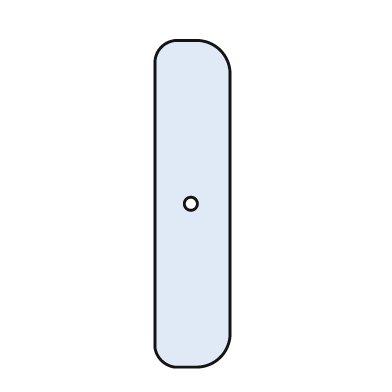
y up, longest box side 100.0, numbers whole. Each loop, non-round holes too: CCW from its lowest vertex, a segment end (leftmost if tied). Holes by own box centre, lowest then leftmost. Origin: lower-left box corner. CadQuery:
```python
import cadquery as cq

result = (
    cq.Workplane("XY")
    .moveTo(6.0, 0.0)
    .lineTo(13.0, 0.0)
    .threePointArc((20.0, 3.0), (23.0, 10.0))
    .lineTo(23.0, 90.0)
    .threePointArc((20.0, 97.0), (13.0, 100.0))
    .lineTo(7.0, 100.0)
    .threePointArc((2.0, 98.0), (0.0, 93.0))
    .lineTo(0.0, 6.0)
    .threePointArc((2.0, 2.0), (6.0, 0.0))
    .close()
    .moveTo(11.0, 50.0)
    .circle(2.0)
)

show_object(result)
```